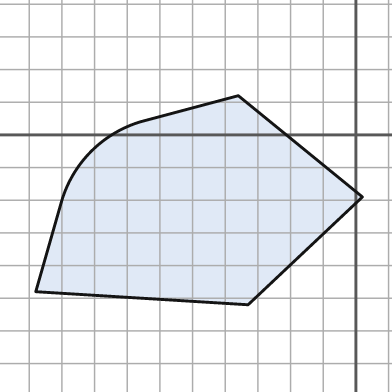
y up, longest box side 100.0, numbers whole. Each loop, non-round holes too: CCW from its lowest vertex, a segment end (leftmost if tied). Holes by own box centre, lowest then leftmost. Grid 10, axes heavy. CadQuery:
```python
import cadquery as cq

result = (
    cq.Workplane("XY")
    .moveTo(-33.0, -52.0)
    .lineTo(2.0, -19.0)
    .lineTo(-36.0, 12.0)
    .lineTo(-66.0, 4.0)
    .threePointArc((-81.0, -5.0), (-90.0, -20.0))
    .lineTo(-98.0, -48.0)
    .close()
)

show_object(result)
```